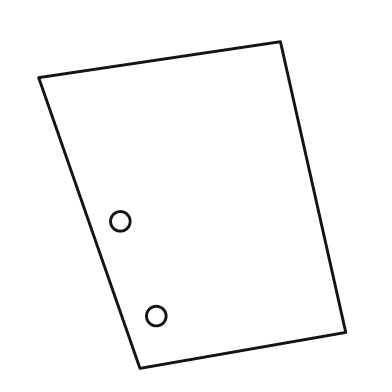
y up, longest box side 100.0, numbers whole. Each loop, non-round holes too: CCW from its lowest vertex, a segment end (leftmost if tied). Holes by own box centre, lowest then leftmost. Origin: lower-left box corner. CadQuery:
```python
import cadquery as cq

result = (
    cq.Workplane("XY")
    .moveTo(31.0, 0.0)
    .lineTo(94.0, 11.0)
    .lineTo(74.0, 100.0)
    .lineTo(0.0, 89.0)
    .close()
    .moveTo(36.0, 16.0)
    .circle(3.0)
    .moveTo(25.0, 45.0)
    .circle(3.0)
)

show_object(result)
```